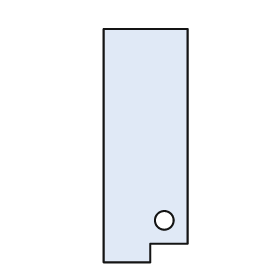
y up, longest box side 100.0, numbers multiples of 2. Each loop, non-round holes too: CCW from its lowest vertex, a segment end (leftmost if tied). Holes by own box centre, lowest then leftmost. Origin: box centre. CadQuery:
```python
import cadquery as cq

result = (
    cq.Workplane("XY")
    .moveTo(-18.0, -50.0)
    .lineTo(2.0, -50.0)
    .lineTo(2.0, -42.0)
    .lineTo(18.0, -42.0)
    .lineTo(18.0, 50.0)
    .lineTo(-18.0, 50.0)
    .close()
    .moveTo(8.0, -32.0)
    .circle(4.0)
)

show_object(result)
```